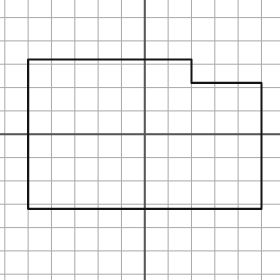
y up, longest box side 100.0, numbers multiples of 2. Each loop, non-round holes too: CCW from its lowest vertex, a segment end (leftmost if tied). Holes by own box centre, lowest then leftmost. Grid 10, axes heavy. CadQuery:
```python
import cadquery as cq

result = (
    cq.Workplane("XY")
    .moveTo(-50.0, -32.0)
    .lineTo(50.0, -32.0)
    .lineTo(50.0, 22.0)
    .lineTo(20.0, 22.0)
    .lineTo(20.0, 32.0)
    .lineTo(-50.0, 32.0)
    .close()
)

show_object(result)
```